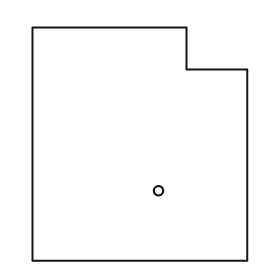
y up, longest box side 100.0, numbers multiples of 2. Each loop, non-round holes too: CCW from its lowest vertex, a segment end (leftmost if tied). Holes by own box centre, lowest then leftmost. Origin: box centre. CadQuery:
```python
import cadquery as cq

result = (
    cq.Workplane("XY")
    .moveTo(-46.0, -50.0)
    .lineTo(46.0, -50.0)
    .lineTo(46.0, 32.0)
    .lineTo(20.0, 32.0)
    .lineTo(20.0, 50.0)
    .lineTo(-46.0, 50.0)
    .close()
    .moveTo(8.0, -20.0)
    .circle(2.0)
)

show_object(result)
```